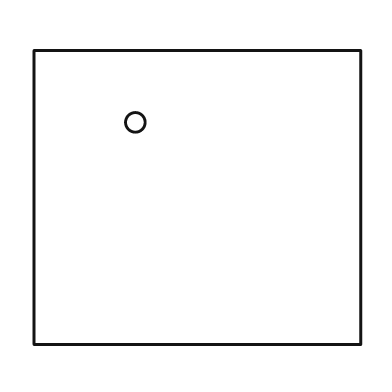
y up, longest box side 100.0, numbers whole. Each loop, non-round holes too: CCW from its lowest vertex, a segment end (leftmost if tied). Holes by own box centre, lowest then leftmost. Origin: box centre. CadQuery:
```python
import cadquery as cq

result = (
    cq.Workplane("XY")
    .moveTo(-50.0, -45.0)
    .lineTo(50.0, -45.0)
    .lineTo(50.0, 45.0)
    .lineTo(-50.0, 45.0)
    .close()
    .moveTo(-19.0, 23.0)
    .circle(3.0)
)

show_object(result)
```